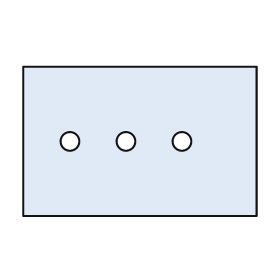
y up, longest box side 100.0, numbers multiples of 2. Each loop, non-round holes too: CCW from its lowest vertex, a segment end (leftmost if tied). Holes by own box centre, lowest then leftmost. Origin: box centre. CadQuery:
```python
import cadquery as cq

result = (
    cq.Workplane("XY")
    .moveTo(-50.0, -32.0)
    .lineTo(50.0, -32.0)
    .lineTo(50.0, 32.0)
    .lineTo(-50.0, 32.0)
    .close()
    .moveTo(-30.0, 0.0)
    .circle(4.0)
    .moveTo(-6.0, 0.0)
    .circle(4.0)
    .moveTo(18.0, 0.0)
    .circle(4.0)
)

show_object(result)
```